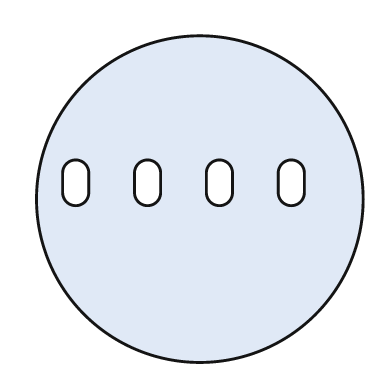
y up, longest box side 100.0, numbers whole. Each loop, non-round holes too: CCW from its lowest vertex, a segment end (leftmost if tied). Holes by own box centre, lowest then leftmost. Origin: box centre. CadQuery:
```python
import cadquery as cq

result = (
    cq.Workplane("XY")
    .moveTo(0.0, 0.0)
    .circle(50.0)
    .moveTo(-42.0, 2.0)
    .threePointArc((-38.0, -2.0), (-34.0, 2.0))
    .lineTo(-34.0, 8.0)
    .threePointArc((-38.0, 12.0), (-42.0, 8.0))
    .close()
    .moveTo(-20.0, 2.0)
    .threePointArc((-16.0, -2.0), (-12.0, 2.0))
    .lineTo(-12.0, 8.0)
    .threePointArc((-16.0, 12.0), (-20.0, 8.0))
    .close()
    .moveTo(2.0, 2.0)
    .threePointArc((6.0, -2.0), (10.0, 2.0))
    .lineTo(10.0, 8.0)
    .threePointArc((6.0, 12.0), (2.0, 8.0))
    .close()
    .moveTo(24.0, 2.0)
    .threePointArc((28.0, -2.0), (32.0, 2.0))
    .lineTo(32.0, 8.0)
    .threePointArc((28.0, 12.0), (24.0, 8.0))
    .close()
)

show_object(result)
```